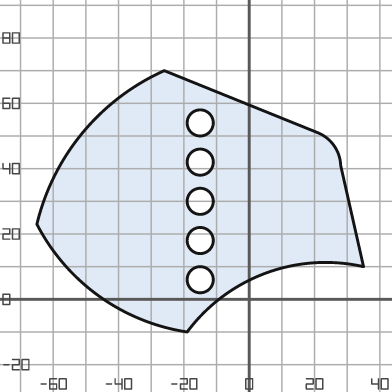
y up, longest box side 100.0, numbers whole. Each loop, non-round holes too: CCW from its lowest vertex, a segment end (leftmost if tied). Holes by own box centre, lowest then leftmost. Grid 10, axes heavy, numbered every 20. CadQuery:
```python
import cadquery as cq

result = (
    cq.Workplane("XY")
    .moveTo(-19.0, -10.0)
    .threePointArc((5.0, 8.0), (35.0, 10.0))
    .lineTo(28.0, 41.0)
    .threePointArc((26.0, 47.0), (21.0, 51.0))
    .lineTo(-26.0, 70.0)
    .threePointArc((-51.0, 51.0), (-65.0, 23.0))
    .threePointArc((-46.0, 1.0), (-19.0, -10.0))
    .close()
    .moveTo(-15.0, 6.0)
    .circle(4.0)
    .moveTo(-15.0, 18.0)
    .circle(4.0)
    .moveTo(-15.0, 30.0)
    .circle(4.0)
    .moveTo(-15.0, 42.0)
    .circle(4.0)
    .moveTo(-15.0, 54.0)
    .circle(4.0)
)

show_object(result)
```